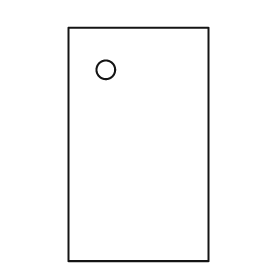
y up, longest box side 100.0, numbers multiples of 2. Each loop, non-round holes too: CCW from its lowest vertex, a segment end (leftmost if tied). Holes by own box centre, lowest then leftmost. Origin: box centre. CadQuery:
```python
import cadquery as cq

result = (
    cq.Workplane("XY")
    .moveTo(-30.0, -50.0)
    .lineTo(30.0, -50.0)
    .lineTo(30.0, 50.0)
    .lineTo(-30.0, 50.0)
    .close()
    .moveTo(-14.0, 32.0)
    .circle(4.0)
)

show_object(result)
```